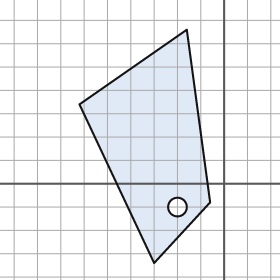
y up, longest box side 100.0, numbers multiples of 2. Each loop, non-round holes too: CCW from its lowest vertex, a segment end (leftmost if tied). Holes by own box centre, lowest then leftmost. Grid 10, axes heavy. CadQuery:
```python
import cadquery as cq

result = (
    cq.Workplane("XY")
    .moveTo(-30.0, -34.0)
    .lineTo(-6.0, -8.0)
    .lineTo(-16.0, 66.0)
    .lineTo(-62.0, 34.0)
    .close()
    .moveTo(-20.0, -10.0)
    .circle(4.0)
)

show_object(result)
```